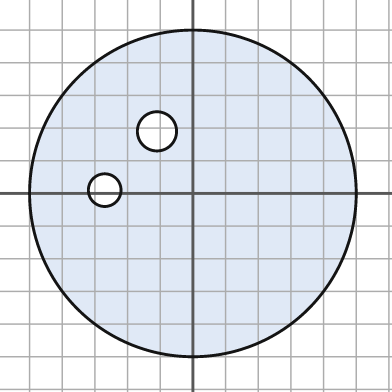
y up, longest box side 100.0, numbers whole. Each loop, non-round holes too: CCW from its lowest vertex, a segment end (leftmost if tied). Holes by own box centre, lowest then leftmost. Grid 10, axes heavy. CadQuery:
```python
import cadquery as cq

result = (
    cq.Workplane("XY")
    .moveTo(0.0, 0.0)
    .circle(50.0)
    .moveTo(-27.0, 1.0)
    .circle(5.0)
    .moveTo(-11.0, 19.0)
    .circle(6.0)
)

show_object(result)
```